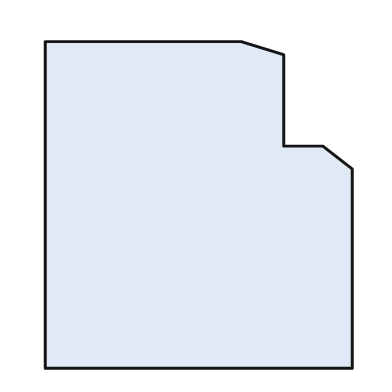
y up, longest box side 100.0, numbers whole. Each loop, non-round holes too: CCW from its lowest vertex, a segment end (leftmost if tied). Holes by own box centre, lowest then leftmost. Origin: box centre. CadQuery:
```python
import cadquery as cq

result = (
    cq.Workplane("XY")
    .moveTo(-47.0, -50.0)
    .lineTo(47.0, -50.0)
    .lineTo(47.0, 11.0)
    .lineTo(38.0, 18.0)
    .lineTo(26.0, 18.0)
    .lineTo(26.0, 46.0)
    .lineTo(13.0, 50.0)
    .lineTo(-47.0, 50.0)
    .close()
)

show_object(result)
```